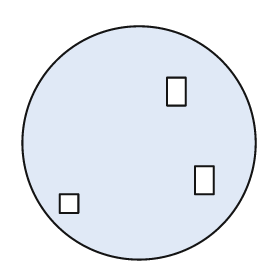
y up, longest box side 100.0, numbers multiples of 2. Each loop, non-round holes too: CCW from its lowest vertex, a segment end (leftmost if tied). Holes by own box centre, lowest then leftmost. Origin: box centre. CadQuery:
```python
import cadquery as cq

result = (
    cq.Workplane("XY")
    .moveTo(0.0, 0.0)
    .circle(50.0)
    .moveTo(-34.0, -30.0)
    .lineTo(-26.0, -30.0)
    .lineTo(-26.0, -22.0)
    .lineTo(-34.0, -22.0)
    .close()
    .moveTo(24.0, -22.0)
    .lineTo(32.0, -22.0)
    .lineTo(32.0, -10.0)
    .lineTo(24.0, -10.0)
    .close()
    .moveTo(12.0, 16.0)
    .lineTo(20.0, 16.0)
    .lineTo(20.0, 28.0)
    .lineTo(12.0, 28.0)
    .close()
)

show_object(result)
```